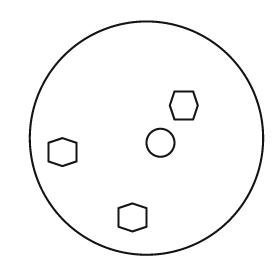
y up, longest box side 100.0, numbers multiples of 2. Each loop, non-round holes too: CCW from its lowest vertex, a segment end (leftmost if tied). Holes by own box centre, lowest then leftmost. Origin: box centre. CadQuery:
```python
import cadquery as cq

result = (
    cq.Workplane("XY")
    .moveTo(0.0, 0.0)
    .circle(50.0)
    .moveTo(-6.0, -40.0)
    .lineTo(0.0, -38.0)
    .lineTo(0.0, -30.0)
    .lineTo(-6.0, -28.0)
    .lineTo(-12.0, -30.0)
    .lineTo(-12.0, -38.0)
    .close()
    .moveTo(-36.0, -12.0)
    .lineTo(-30.0, -10.0)
    .lineTo(-30.0, -2.0)
    .lineTo(-36.0, 0.0)
    .lineTo(-42.0, -2.0)
    .lineTo(-42.0, -10.0)
    .close()
    .moveTo(6.0, -2.0)
    .circle(6.0)
    .moveTo(12.0, 8.0)
    .lineTo(20.0, 8.0)
    .lineTo(22.0, 14.0)
    .lineTo(20.0, 20.0)
    .lineTo(12.0, 20.0)
    .lineTo(10.0, 14.0)
    .close()
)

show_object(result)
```